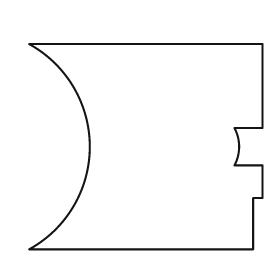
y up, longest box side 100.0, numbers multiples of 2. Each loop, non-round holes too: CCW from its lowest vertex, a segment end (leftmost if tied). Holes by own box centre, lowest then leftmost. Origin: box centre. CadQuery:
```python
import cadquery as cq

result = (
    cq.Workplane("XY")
    .moveTo(-50.0, -44.0)
    .lineTo(46.0, -44.0)
    .lineTo(46.0, -22.0)
    .lineTo(50.0, -22.0)
    .lineTo(50.0, -8.0)
    .lineTo(38.0, -8.0)
    .threePointArc((40.0, 0.0), (38.0, 8.0))
    .lineTo(50.0, 8.0)
    .lineTo(50.0, 44.0)
    .lineTo(-50.0, 44.0)
    .threePointArc((-24.0, 0.0), (-50.0, -44.0))
    .close()
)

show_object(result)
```